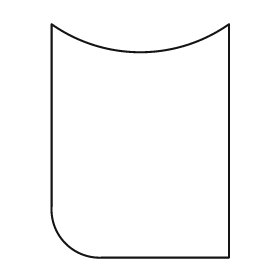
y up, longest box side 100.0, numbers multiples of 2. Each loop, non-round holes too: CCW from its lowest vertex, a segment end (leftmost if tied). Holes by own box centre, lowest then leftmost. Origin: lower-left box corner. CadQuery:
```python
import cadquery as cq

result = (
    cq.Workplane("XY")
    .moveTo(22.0, 0.0)
    .lineTo(76.0, 0.0)
    .lineTo(76.0, 100.0)
    .threePointArc((38.0, 88.0), (0.0, 100.0))
    .lineTo(0.0, 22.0)
    .threePointArc((6.0, 6.0), (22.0, 0.0))
    .close()
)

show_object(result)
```